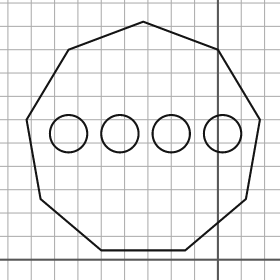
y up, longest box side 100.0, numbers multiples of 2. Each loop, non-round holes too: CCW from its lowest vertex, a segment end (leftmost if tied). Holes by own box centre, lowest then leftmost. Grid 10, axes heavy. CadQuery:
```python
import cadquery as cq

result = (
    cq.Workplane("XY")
    .moveTo(-50.0, 4.0)
    .lineTo(-14.0, 4.0)
    .lineTo(12.0, 26.0)
    .lineTo(18.0, 60.0)
    .lineTo(0.0, 90.0)
    .lineTo(-32.0, 102.0)
    .lineTo(-64.0, 90.0)
    .lineTo(-82.0, 60.0)
    .lineTo(-76.0, 26.0)
    .close()
    .moveTo(-64.0, 54.0)
    .circle(8.0)
    .moveTo(-42.0, 54.0)
    .circle(8.0)
    .moveTo(-20.0, 54.0)
    .circle(8.0)
    .moveTo(2.0, 54.0)
    .circle(8.0)
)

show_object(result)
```